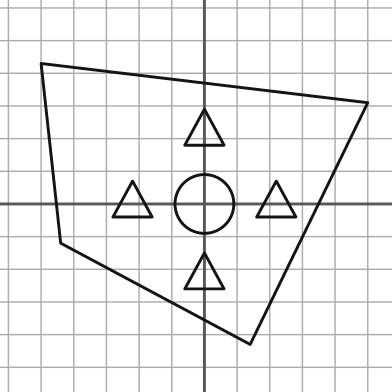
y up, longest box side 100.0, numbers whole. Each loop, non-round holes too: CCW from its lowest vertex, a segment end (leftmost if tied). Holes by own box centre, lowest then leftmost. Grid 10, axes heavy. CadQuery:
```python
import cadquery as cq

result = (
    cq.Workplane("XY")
    .moveTo(14.0, -43.0)
    .lineTo(50.0, 31.0)
    .lineTo(-50.0, 43.0)
    .lineTo(-44.0, -12.0)
    .close()
    .moveTo(-6.0, -26.0)
    .lineTo(6.0, -26.0)
    .lineTo(0.0, -15.0)
    .close()
    .moveTo(0.0, 0.0)
    .circle(9.0)
    .moveTo(-28.0, -4.0)
    .lineTo(-16.0, -4.0)
    .lineTo(-22.0, 7.0)
    .close()
    .moveTo(16.0, -4.0)
    .lineTo(28.0, -4.0)
    .lineTo(22.0, 7.0)
    .close()
    .moveTo(-6.0, 18.0)
    .lineTo(6.0, 18.0)
    .lineTo(0.0, 29.0)
    .close()
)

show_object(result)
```